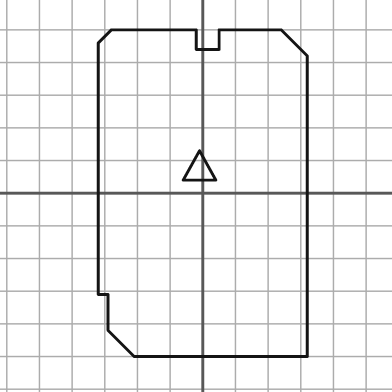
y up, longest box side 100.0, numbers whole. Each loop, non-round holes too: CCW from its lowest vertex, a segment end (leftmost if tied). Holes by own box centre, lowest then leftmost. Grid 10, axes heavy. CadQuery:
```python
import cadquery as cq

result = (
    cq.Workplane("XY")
    .moveTo(-21.0, -50.0)
    .lineTo(32.0, -50.0)
    .lineTo(32.0, 42.0)
    .lineTo(24.0, 50.0)
    .lineTo(5.0, 50.0)
    .lineTo(5.0, 44.0)
    .lineTo(-2.0, 44.0)
    .lineTo(-2.0, 50.0)
    .lineTo(-28.0, 50.0)
    .lineTo(-32.0, 46.0)
    .lineTo(-32.0, -31.0)
    .lineTo(-29.0, -31.0)
    .lineTo(-29.0, -42.0)
    .close()
    .moveTo(-6.0, 4.0)
    .lineTo(4.0, 4.0)
    .lineTo(-1.0, 13.0)
    .close()
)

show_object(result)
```